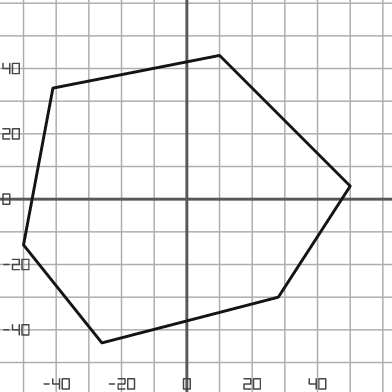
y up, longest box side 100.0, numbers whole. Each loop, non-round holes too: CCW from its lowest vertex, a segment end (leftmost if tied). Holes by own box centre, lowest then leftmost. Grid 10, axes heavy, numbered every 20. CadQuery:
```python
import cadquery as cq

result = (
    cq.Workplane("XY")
    .moveTo(-26.0, -44.0)
    .lineTo(28.0, -30.0)
    .lineTo(50.0, 4.0)
    .lineTo(10.0, 44.0)
    .lineTo(-41.0, 34.0)
    .lineTo(-50.0, -14.0)
    .close()
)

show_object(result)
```